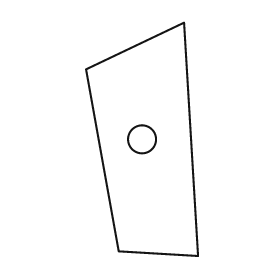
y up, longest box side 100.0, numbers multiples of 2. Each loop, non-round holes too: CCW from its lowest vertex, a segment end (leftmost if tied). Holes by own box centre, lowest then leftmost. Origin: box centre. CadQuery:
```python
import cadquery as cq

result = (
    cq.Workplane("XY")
    .moveTo(24.0, -50.0)
    .lineTo(18.0, 50.0)
    .lineTo(-24.0, 30.0)
    .lineTo(-10.0, -48.0)
    .close()
    .moveTo(0.0, 0.0)
    .circle(6.0)
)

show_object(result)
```